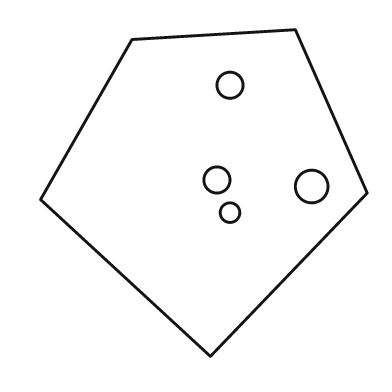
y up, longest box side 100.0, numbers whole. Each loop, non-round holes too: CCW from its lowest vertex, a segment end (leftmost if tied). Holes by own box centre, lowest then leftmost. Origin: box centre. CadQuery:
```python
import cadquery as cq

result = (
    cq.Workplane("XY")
    .moveTo(2.0, -50.0)
    .lineTo(50.0, 0.0)
    .lineTo(28.0, 50.0)
    .lineTo(-22.0, 47.0)
    .lineTo(-50.0, -2.0)
    .close()
    .moveTo(8.0, -6.0)
    .circle(3.0)
    .moveTo(33.0, 2.0)
    .circle(5.0)
    .moveTo(4.0, 4.0)
    .circle(4.0)
    .moveTo(8.0, 33.0)
    .circle(4.0)
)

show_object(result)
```